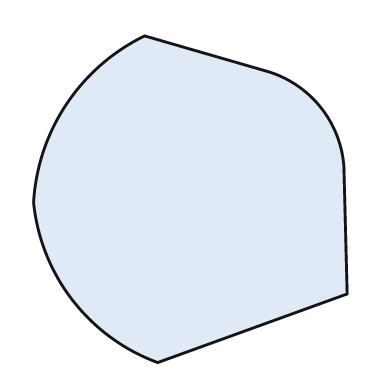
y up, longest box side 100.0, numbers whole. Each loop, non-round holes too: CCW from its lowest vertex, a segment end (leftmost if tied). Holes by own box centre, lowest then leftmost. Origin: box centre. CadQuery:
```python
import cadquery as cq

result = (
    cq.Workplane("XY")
    .moveTo(-10.0, -50.0)
    .lineTo(48.0, -29.0)
    .lineTo(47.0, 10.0)
    .threePointArc((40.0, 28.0), (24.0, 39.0))
    .lineTo(-14.0, 50.0)
    .threePointArc((-38.0, 29.0), (-48.0, -1.0))
    .threePointArc((-36.0, -31.0), (-10.0, -50.0))
    .close()
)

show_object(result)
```